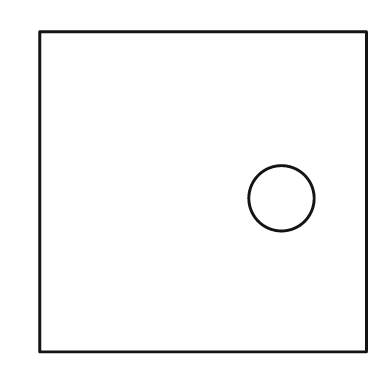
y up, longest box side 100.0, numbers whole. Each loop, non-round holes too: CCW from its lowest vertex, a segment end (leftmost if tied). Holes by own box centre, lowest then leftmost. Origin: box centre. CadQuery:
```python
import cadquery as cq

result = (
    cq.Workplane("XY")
    .moveTo(-50.0, -49.0)
    .lineTo(50.0, -49.0)
    .lineTo(50.0, 49.0)
    .lineTo(-50.0, 49.0)
    .close()
    .moveTo(24.0, -2.0)
    .circle(10.0)
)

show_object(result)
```